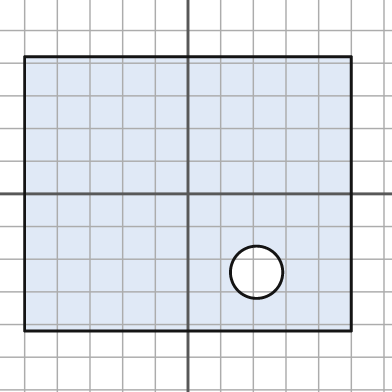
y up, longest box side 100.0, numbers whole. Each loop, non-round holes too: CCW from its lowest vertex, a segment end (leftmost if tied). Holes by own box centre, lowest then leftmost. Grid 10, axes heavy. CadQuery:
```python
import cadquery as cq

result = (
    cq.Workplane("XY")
    .moveTo(-50.0, -42.0)
    .lineTo(50.0, -42.0)
    .lineTo(50.0, 42.0)
    .lineTo(-50.0, 42.0)
    .close()
    .moveTo(21.0, -24.0)
    .circle(8.0)
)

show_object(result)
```